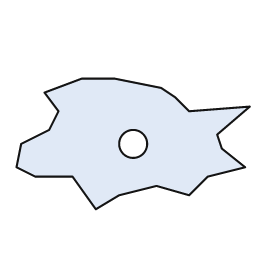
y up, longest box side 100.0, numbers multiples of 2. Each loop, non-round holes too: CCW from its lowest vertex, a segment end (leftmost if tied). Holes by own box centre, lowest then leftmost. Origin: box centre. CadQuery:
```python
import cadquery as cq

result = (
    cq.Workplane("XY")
    .moveTo(-16.0, -28.0)
    .lineTo(-6.0, -22.0)
    .lineTo(10.0, -18.0)
    .lineTo(24.0, -22.0)
    .lineTo(32.0, -14.0)
    .lineTo(48.0, -10.0)
    .lineTo(38.0, -2.0)
    .lineTo(36.0, 4.0)
    .lineTo(50.0, 16.0)
    .lineTo(24.0, 14.0)
    .lineTo(18.0, 20.0)
    .lineTo(12.0, 24.0)
    .lineTo(-8.0, 28.0)
    .lineTo(-22.0, 28.0)
    .lineTo(-38.0, 22.0)
    .lineTo(-32.0, 14.0)
    .lineTo(-36.0, 6.0)
    .lineTo(-48.0, 0.0)
    .lineTo(-50.0, -10.0)
    .lineTo(-42.0, -14.0)
    .lineTo(-26.0, -14.0)
    .close()
    .moveTo(0.0, 0.0)
    .circle(6.0)
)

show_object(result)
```